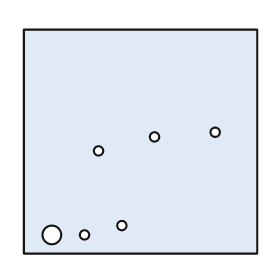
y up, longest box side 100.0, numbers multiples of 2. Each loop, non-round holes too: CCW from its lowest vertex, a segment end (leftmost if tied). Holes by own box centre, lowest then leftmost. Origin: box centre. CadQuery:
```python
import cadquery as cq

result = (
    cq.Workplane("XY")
    .moveTo(-50.0, -48.0)
    .lineTo(50.0, -48.0)
    .lineTo(50.0, 48.0)
    .lineTo(-50.0, 48.0)
    .close()
    .moveTo(-38.0, -40.0)
    .circle(4.0)
    .moveTo(-24.0, -40.0)
    .circle(2.0)
    .moveTo(-8.0, -36.0)
    .circle(2.0)
    .moveTo(-18.0, -4.0)
    .circle(2.0)
    .moveTo(6.0, 2.0)
    .circle(2.0)
    .moveTo(32.0, 4.0)
    .circle(2.0)
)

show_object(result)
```